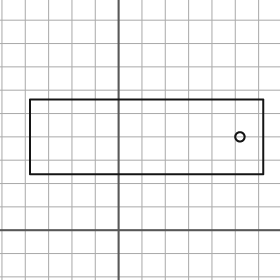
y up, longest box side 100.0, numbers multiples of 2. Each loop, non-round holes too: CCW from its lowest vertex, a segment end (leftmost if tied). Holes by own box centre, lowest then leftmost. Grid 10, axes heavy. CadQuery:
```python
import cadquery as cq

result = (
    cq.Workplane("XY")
    .moveTo(-38.0, 24.0)
    .lineTo(62.0, 24.0)
    .lineTo(62.0, 56.0)
    .lineTo(-38.0, 56.0)
    .close()
    .moveTo(52.0, 40.0)
    .circle(2.0)
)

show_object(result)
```